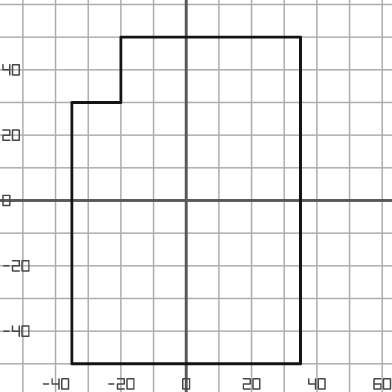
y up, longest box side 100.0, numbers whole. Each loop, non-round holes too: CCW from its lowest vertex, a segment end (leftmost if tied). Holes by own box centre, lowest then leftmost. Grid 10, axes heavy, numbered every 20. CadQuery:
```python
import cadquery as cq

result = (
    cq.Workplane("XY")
    .moveTo(-35.0, -50.0)
    .lineTo(35.0, -50.0)
    .lineTo(35.0, 50.0)
    .lineTo(-20.0, 50.0)
    .lineTo(-20.0, 30.0)
    .lineTo(-35.0, 30.0)
    .close()
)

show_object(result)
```